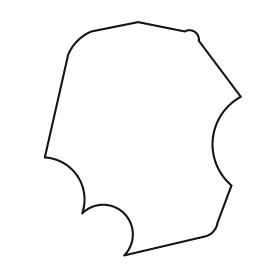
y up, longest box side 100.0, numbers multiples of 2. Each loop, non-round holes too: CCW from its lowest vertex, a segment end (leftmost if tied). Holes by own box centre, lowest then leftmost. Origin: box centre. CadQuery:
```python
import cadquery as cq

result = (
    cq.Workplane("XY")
    .moveTo(-8.0, -50.0)
    .lineTo(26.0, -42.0)
    .threePointArc((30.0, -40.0), (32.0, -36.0))
    .lineTo(38.0, -20.0)
    .threePointArc((30.0, 0.0), (42.0, 18.0))
    .lineTo(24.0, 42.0)
    .threePointArc((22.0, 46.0), (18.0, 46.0))
    .lineTo(-2.0, 50.0)
    .lineTo(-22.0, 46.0)
    .threePointArc((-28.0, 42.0), (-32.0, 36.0))
    .lineTo(-42.0, -8.0)
    .threePointArc((-28.0, -16.0), (-26.0, -32.0))
    .threePointArc((-8.0, -32.0), (-8.0, -50.0))
    .close()
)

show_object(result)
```